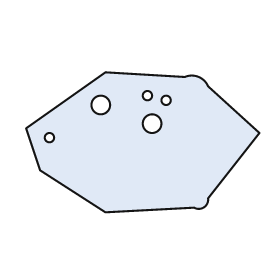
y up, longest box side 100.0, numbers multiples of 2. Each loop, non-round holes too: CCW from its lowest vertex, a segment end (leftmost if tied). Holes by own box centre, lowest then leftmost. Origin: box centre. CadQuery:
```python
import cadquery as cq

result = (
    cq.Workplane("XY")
    .moveTo(-16.0, -30.0)
    .lineTo(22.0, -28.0)
    .threePointArc((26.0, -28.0), (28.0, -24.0))
    .lineTo(50.0, 4.0)
    .lineTo(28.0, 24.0)
    .threePointArc((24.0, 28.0), (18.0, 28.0))
    .lineTo(-16.0, 30.0)
    .lineTo(-50.0, 6.0)
    .lineTo(-44.0, -12.0)
    .close()
    .moveTo(-40.0, 2.0)
    .circle(2.0)
    .moveTo(4.0, 8.0)
    .circle(4.0)
    .moveTo(-18.0, 16.0)
    .circle(4.0)
    .moveTo(10.0, 18.0)
    .circle(2.0)
    .moveTo(2.0, 20.0)
    .circle(2.0)
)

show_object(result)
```